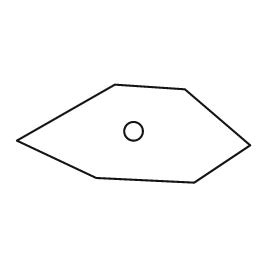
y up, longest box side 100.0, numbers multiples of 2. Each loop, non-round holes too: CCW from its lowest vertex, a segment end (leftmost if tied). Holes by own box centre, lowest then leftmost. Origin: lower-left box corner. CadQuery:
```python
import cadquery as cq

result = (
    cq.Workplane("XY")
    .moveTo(76.0, 0.0)
    .lineTo(100.0, 16.0)
    .lineTo(72.0, 40.0)
    .lineTo(42.0, 42.0)
    .lineTo(0.0, 18.0)
    .lineTo(34.0, 2.0)
    .close()
    .moveTo(50.0, 22.0)
    .circle(4.0)
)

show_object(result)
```